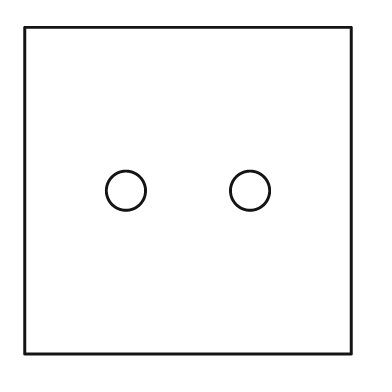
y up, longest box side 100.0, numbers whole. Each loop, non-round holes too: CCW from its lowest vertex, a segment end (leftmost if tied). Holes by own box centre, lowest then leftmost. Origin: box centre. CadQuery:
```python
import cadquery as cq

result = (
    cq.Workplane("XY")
    .moveTo(-50.0, -50.0)
    .lineTo(50.0, -50.0)
    .lineTo(50.0, 50.0)
    .lineTo(-50.0, 50.0)
    .close()
    .moveTo(-19.0, 0.0)
    .circle(6.0)
    .moveTo(19.0, 0.0)
    .circle(6.0)
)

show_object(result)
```